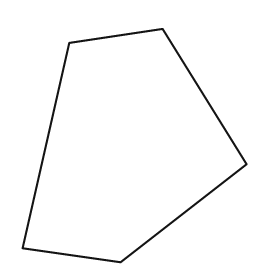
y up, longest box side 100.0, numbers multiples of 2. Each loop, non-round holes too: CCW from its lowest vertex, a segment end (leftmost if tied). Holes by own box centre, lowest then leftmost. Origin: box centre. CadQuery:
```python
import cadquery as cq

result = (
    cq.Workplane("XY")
    .moveTo(-6.0, -50.0)
    .lineTo(48.0, -8.0)
    .lineTo(12.0, 50.0)
    .lineTo(-28.0, 44.0)
    .lineTo(-48.0, -44.0)
    .close()
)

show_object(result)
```